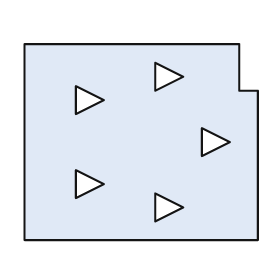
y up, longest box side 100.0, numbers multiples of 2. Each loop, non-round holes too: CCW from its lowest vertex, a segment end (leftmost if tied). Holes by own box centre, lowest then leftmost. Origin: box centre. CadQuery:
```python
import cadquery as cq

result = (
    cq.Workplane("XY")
    .moveTo(-50.0, -42.0)
    .lineTo(50.0, -42.0)
    .lineTo(50.0, 22.0)
    .lineTo(42.0, 22.0)
    .lineTo(42.0, 42.0)
    .lineTo(-50.0, 42.0)
    .close()
    .moveTo(6.0, -34.0)
    .lineTo(18.0, -28.0)
    .lineTo(6.0, -22.0)
    .close()
    .moveTo(-28.0, -24.0)
    .lineTo(-16.0, -18.0)
    .lineTo(-28.0, -12.0)
    .close()
    .moveTo(26.0, -6.0)
    .lineTo(38.0, 0.0)
    .lineTo(26.0, 6.0)
    .close()
    .moveTo(-28.0, 12.0)
    .lineTo(-16.0, 18.0)
    .lineTo(-28.0, 24.0)
    .close()
    .moveTo(6.0, 22.0)
    .lineTo(18.0, 28.0)
    .lineTo(6.0, 34.0)
    .close()
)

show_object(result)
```